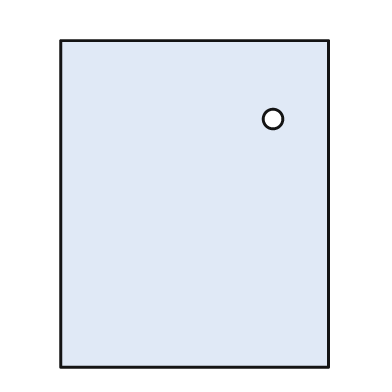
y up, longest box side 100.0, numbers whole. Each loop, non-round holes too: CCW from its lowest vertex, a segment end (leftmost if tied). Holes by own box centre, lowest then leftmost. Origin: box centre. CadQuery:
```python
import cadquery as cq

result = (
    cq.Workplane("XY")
    .moveTo(-41.0, -50.0)
    .lineTo(41.0, -50.0)
    .lineTo(41.0, 50.0)
    .lineTo(-41.0, 50.0)
    .close()
    .moveTo(24.0, 26.0)
    .circle(3.0)
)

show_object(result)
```